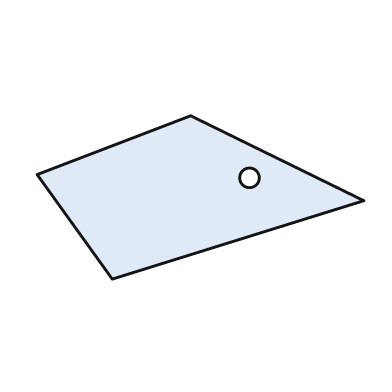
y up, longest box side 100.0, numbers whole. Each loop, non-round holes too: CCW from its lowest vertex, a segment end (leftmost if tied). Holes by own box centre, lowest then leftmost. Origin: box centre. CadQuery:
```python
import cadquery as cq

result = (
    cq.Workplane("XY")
    .moveTo(-27.0, -25.0)
    .lineTo(50.0, -1.0)
    .lineTo(-3.0, 25.0)
    .lineTo(-50.0, 7.0)
    .close()
    .moveTo(15.0, 6.0)
    .circle(3.0)
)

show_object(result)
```